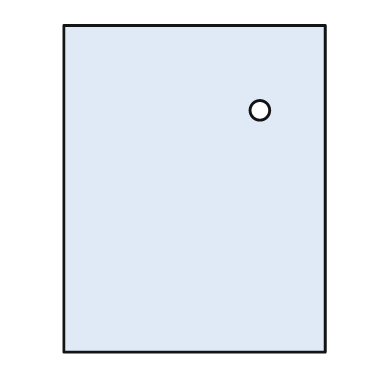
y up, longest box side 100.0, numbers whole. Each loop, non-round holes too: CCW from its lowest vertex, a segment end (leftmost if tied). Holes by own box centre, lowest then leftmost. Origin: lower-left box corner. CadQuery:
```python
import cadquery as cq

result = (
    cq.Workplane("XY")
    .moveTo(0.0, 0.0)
    .lineTo(80.0, 0.0)
    .lineTo(80.0, 100.0)
    .lineTo(0.0, 100.0)
    .close()
    .moveTo(60.0, 74.0)
    .circle(3.0)
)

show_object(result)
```